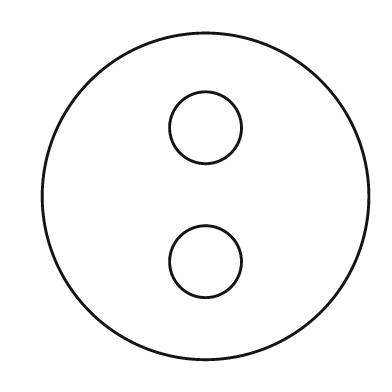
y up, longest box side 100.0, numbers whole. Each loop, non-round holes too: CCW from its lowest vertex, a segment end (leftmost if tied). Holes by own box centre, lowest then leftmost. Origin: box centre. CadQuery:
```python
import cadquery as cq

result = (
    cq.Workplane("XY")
    .moveTo(0.0, 0.0)
    .circle(50.0)
    .moveTo(0.0, -20.0)
    .circle(11.0)
    .moveTo(0.0, 21.0)
    .circle(11.0)
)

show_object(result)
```